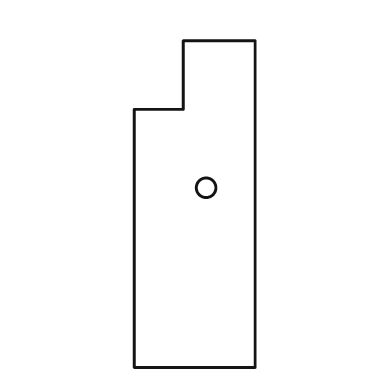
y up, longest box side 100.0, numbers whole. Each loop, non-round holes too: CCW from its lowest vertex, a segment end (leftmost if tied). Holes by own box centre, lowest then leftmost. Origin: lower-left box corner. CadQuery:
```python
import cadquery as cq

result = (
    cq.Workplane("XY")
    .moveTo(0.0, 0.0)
    .lineTo(37.0, 0.0)
    .lineTo(37.0, 100.0)
    .lineTo(15.0, 100.0)
    .lineTo(15.0, 79.0)
    .lineTo(0.0, 79.0)
    .close()
    .moveTo(22.0, 55.0)
    .circle(3.0)
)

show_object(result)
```